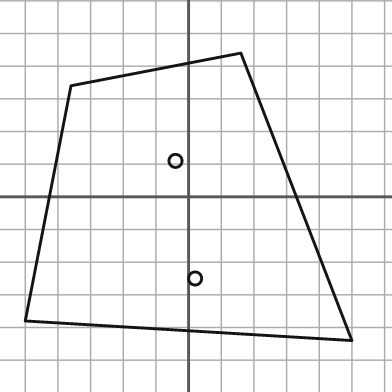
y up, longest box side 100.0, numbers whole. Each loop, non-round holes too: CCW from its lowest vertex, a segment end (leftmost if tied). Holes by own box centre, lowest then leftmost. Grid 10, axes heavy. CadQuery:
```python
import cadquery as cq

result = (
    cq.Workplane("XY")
    .moveTo(50.0, -44.0)
    .lineTo(16.0, 44.0)
    .lineTo(-36.0, 34.0)
    .lineTo(-50.0, -38.0)
    .close()
    .moveTo(2.0, -25.0)
    .circle(2.0)
    .moveTo(-4.0, 11.0)
    .circle(2.0)
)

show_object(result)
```